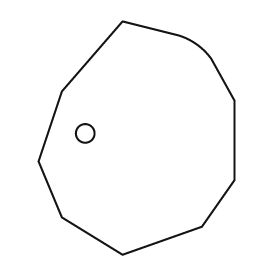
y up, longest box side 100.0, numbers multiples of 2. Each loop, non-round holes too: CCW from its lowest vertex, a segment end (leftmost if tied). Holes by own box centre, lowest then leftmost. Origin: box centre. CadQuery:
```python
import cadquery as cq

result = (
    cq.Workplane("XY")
    .moveTo(-6.0, -50.0)
    .lineTo(28.0, -38.0)
    .lineTo(42.0, -18.0)
    .lineTo(42.0, 16.0)
    .lineTo(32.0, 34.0)
    .threePointArc((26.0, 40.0), (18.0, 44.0))
    .lineTo(-6.0, 50.0)
    .lineTo(-32.0, 20.0)
    .lineTo(-42.0, -10.0)
    .lineTo(-32.0, -34.0)
    .close()
    .moveTo(-22.0, 2.0)
    .circle(4.0)
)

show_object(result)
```